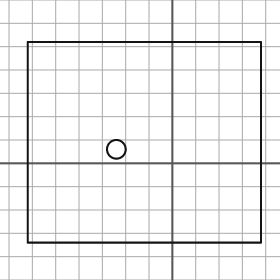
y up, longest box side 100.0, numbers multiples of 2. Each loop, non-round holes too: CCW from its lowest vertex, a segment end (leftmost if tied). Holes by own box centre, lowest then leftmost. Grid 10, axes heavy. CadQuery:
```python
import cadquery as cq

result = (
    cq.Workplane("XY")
    .moveTo(-62.0, -34.0)
    .lineTo(38.0, -34.0)
    .lineTo(38.0, 52.0)
    .lineTo(-62.0, 52.0)
    .close()
    .moveTo(-24.0, 6.0)
    .circle(4.0)
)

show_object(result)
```